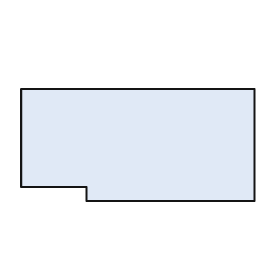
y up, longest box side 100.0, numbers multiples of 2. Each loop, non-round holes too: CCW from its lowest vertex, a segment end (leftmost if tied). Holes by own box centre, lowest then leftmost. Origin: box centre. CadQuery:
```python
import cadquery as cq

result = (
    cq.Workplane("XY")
    .moveTo(-22.0, -24.0)
    .lineTo(50.0, -24.0)
    .lineTo(50.0, 24.0)
    .lineTo(-50.0, 24.0)
    .lineTo(-50.0, -18.0)
    .lineTo(-22.0, -18.0)
    .close()
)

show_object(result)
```